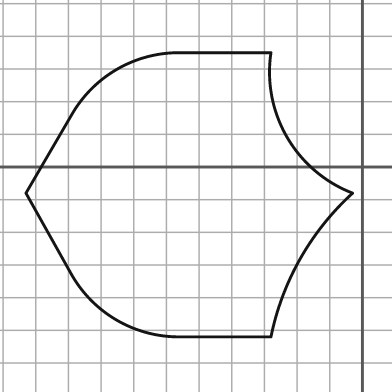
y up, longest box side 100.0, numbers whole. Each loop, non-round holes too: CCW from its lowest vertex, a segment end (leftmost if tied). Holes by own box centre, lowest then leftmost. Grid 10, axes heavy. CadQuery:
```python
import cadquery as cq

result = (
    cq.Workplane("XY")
    .moveTo(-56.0, -52.0)
    .lineTo(-28.0, -52.0)
    .threePointArc((-19.0, -28.0), (-3.0, -8.0))
    .threePointArc((-23.0, 9.0), (-28.0, 35.0))
    .lineTo(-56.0, 35.0)
    .threePointArc((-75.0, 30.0), (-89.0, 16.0))
    .lineTo(-103.0, -8.0)
    .lineTo(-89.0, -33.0)
    .threePointArc((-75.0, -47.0), (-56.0, -52.0))
    .close()
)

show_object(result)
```